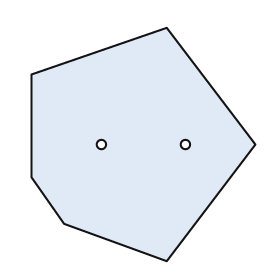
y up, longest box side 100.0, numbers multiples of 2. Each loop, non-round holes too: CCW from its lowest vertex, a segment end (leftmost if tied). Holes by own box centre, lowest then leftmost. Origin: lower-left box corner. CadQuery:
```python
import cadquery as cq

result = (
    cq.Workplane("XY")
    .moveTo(58.0, 0.0)
    .lineTo(96.0, 50.0)
    .lineTo(58.0, 100.0)
    .lineTo(0.0, 80.0)
    .lineTo(0.0, 36.0)
    .lineTo(14.0, 16.0)
    .close()
    .moveTo(30.0, 50.0)
    .circle(2.0)
    .moveTo(66.0, 50.0)
    .circle(2.0)
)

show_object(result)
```